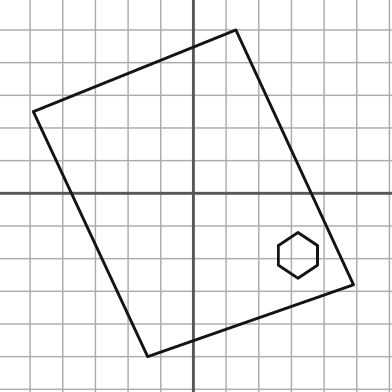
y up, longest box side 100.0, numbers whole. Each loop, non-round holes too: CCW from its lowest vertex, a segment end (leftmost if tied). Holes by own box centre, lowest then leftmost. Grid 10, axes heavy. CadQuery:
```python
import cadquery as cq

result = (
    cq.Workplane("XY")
    .moveTo(-14.0, -50.0)
    .lineTo(49.0, -28.0)
    .lineTo(13.0, 50.0)
    .lineTo(-49.0, 25.0)
    .close()
    .moveTo(32.0, -26.0)
    .lineTo(38.0, -22.0)
    .lineTo(38.0, -16.0)
    .lineTo(32.0, -12.0)
    .lineTo(26.0, -16.0)
    .lineTo(26.0, -22.0)
    .close()
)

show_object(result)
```